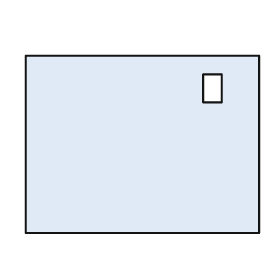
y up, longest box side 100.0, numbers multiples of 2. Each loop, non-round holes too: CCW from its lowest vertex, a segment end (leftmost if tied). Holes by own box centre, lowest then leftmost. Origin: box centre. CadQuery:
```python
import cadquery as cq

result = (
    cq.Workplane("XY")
    .moveTo(-50.0, -38.0)
    .lineTo(50.0, -38.0)
    .lineTo(50.0, 38.0)
    .lineTo(-50.0, 38.0)
    .close()
    .moveTo(26.0, 18.0)
    .lineTo(34.0, 18.0)
    .lineTo(34.0, 30.0)
    .lineTo(26.0, 30.0)
    .close()
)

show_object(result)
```